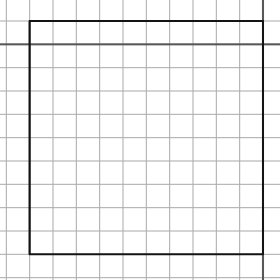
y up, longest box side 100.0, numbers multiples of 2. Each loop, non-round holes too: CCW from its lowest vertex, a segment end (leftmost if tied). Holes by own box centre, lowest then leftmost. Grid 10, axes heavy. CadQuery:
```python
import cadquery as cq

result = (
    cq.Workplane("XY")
    .moveTo(-100.0, -90.0)
    .lineTo(0.0, -90.0)
    .lineTo(0.0, 10.0)
    .lineTo(-100.0, 10.0)
    .close()
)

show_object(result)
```